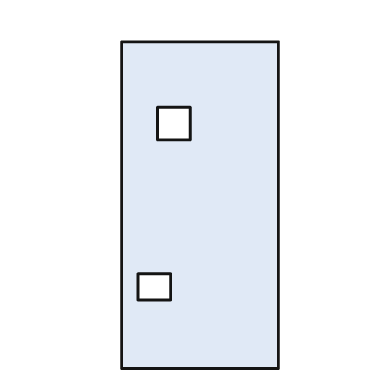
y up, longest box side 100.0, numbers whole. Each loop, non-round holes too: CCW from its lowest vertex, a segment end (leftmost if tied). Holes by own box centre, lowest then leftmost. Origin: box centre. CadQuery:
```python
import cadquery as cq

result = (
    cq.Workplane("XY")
    .moveTo(-24.0, -50.0)
    .lineTo(24.0, -50.0)
    .lineTo(24.0, 50.0)
    .lineTo(-24.0, 50.0)
    .close()
    .moveTo(-19.0, -29.0)
    .lineTo(-9.0, -29.0)
    .lineTo(-9.0, -21.0)
    .lineTo(-19.0, -21.0)
    .close()
    .moveTo(-13.0, 20.0)
    .lineTo(-3.0, 20.0)
    .lineTo(-3.0, 30.0)
    .lineTo(-13.0, 30.0)
    .close()
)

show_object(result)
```